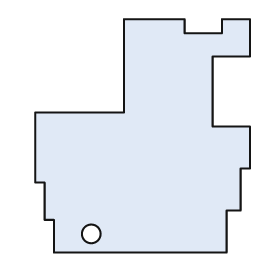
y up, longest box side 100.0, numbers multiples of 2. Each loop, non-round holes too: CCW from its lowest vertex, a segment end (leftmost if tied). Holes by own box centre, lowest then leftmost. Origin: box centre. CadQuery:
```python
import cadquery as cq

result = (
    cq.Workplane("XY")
    .moveTo(-38.0, -50.0)
    .lineTo(36.0, -50.0)
    .lineTo(36.0, -32.0)
    .lineTo(42.0, -32.0)
    .lineTo(42.0, -14.0)
    .lineTo(46.0, -14.0)
    .lineTo(46.0, 4.0)
    .lineTo(30.0, 4.0)
    .lineTo(30.0, 34.0)
    .lineTo(46.0, 34.0)
    .lineTo(46.0, 50.0)
    .lineTo(34.0, 50.0)
    .lineTo(34.0, 44.0)
    .lineTo(18.0, 44.0)
    .lineTo(18.0, 50.0)
    .lineTo(-8.0, 50.0)
    .lineTo(-8.0, 10.0)
    .lineTo(-46.0, 10.0)
    .lineTo(-46.0, -20.0)
    .lineTo(-42.0, -20.0)
    .lineTo(-42.0, -36.0)
    .lineTo(-38.0, -36.0)
    .close()
    .moveTo(-22.0, -42.0)
    .circle(4.0)
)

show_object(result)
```